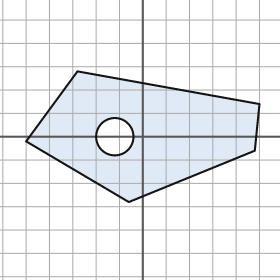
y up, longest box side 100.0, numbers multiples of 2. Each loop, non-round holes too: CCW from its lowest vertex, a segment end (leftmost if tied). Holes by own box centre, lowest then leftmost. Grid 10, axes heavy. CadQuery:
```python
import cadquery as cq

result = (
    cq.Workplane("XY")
    .moveTo(-6.0, -28.0)
    .lineTo(48.0, -6.0)
    .lineTo(50.0, 14.0)
    .lineTo(-28.0, 28.0)
    .lineTo(-50.0, -2.0)
    .close()
    .moveTo(-12.0, 0.0)
    .circle(8.0)
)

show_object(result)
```